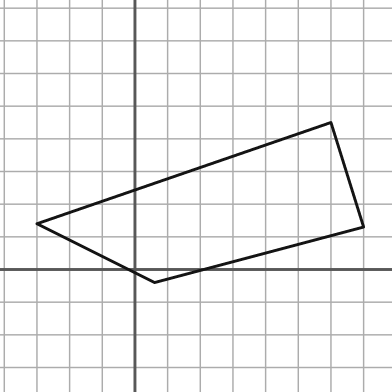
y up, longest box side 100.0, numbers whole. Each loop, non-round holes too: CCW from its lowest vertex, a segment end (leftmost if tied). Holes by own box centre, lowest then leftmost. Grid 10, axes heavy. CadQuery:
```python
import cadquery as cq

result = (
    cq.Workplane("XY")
    .moveTo(6.0, -4.0)
    .lineTo(70.0, 13.0)
    .lineTo(60.0, 45.0)
    .lineTo(-30.0, 14.0)
    .close()
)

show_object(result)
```